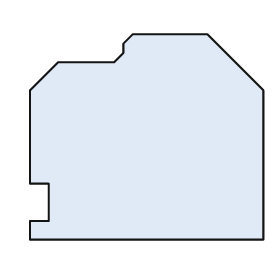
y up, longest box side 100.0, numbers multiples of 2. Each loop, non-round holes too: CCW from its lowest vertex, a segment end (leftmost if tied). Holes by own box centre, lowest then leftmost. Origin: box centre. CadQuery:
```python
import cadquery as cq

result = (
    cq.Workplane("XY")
    .moveTo(-50.0, -44.0)
    .lineTo(50.0, -44.0)
    .lineTo(50.0, 20.0)
    .lineTo(26.0, 44.0)
    .lineTo(-6.0, 44.0)
    .lineTo(-10.0, 40.0)
    .lineTo(-10.0, 36.0)
    .lineTo(-14.0, 32.0)
    .lineTo(-38.0, 32.0)
    .lineTo(-50.0, 20.0)
    .lineTo(-50.0, -20.0)
    .lineTo(-42.0, -20.0)
    .lineTo(-42.0, -36.0)
    .lineTo(-50.0, -36.0)
    .close()
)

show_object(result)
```